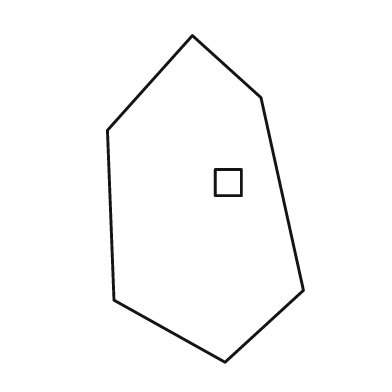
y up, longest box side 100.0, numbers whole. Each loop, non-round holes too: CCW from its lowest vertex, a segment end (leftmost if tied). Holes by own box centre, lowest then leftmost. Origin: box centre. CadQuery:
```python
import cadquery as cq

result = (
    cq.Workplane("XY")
    .moveTo(6.0, -50.0)
    .lineTo(30.0, -28.0)
    .lineTo(17.0, 31.0)
    .lineTo(-4.0, 50.0)
    .lineTo(-30.0, 21.0)
    .lineTo(-28.0, -31.0)
    .close()
    .moveTo(3.0, 1.0)
    .lineTo(11.0, 1.0)
    .lineTo(11.0, 9.0)
    .lineTo(3.0, 9.0)
    .close()
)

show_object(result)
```